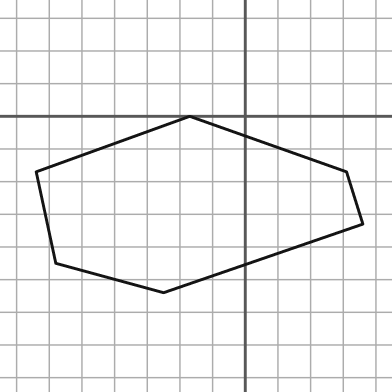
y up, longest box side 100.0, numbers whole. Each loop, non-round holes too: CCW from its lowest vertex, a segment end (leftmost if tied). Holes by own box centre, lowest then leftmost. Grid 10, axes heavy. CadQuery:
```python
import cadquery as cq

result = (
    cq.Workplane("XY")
    .moveTo(-25.0, -54.0)
    .lineTo(36.0, -33.0)
    .lineTo(31.0, -17.0)
    .lineTo(-17.0, 0.0)
    .lineTo(-64.0, -17.0)
    .lineTo(-58.0, -45.0)
    .close()
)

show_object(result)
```